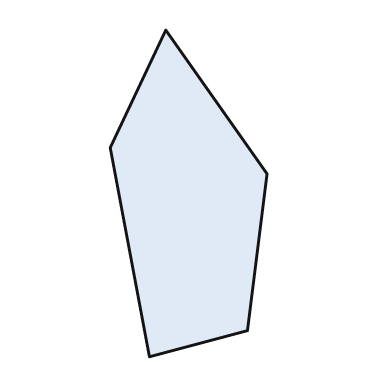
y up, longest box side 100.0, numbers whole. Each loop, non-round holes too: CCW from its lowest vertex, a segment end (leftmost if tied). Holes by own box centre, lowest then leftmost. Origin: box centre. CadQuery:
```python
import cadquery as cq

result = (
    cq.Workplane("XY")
    .moveTo(-12.0, -50.0)
    .lineTo(18.0, -42.0)
    .lineTo(24.0, 6.0)
    .lineTo(-7.0, 50.0)
    .lineTo(-24.0, 14.0)
    .close()
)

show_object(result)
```